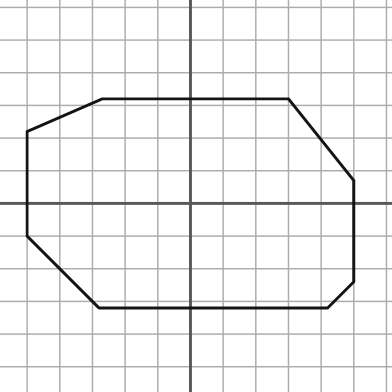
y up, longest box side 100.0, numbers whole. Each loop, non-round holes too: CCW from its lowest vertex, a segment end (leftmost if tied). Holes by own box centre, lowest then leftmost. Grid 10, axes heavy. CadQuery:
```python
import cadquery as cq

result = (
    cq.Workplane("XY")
    .moveTo(-28.0, -32.0)
    .lineTo(42.0, -32.0)
    .lineTo(50.0, -24.0)
    .lineTo(50.0, 7.0)
    .lineTo(30.0, 32.0)
    .lineTo(-27.0, 32.0)
    .lineTo(-50.0, 22.0)
    .lineTo(-50.0, -10.0)
    .close()
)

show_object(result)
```